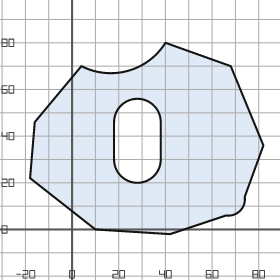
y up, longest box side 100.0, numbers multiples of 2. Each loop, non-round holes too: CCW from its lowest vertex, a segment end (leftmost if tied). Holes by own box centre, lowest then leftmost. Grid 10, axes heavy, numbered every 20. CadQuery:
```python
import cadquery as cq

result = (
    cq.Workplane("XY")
    .moveTo(42.0, -2.0)
    .lineTo(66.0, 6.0)
    .threePointArc((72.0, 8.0), (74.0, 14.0))
    .lineTo(82.0, 36.0)
    .lineTo(68.0, 70.0)
    .lineTo(40.0, 80.0)
    .threePointArc((24.0, 68.0), (4.0, 70.0))
    .lineTo(-16.0, 46.0)
    .lineTo(-18.0, 22.0)
    .lineTo(10.0, 0.0)
    .close()
    .moveTo(18.0, 30.0)
    .threePointArc((28.0, 20.0), (38.0, 30.0))
    .lineTo(38.0, 46.0)
    .threePointArc((28.0, 56.0), (18.0, 46.0))
    .close()
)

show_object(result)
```